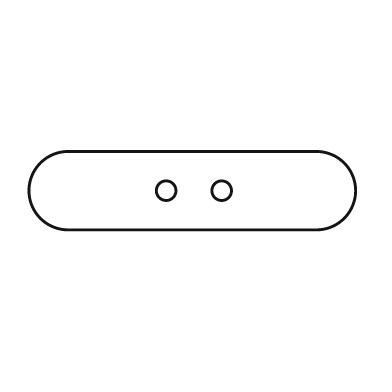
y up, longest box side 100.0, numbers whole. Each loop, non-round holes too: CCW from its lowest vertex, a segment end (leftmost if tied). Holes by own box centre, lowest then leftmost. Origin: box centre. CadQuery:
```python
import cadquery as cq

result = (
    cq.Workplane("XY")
    .moveTo(-38.0, -12.0)
    .lineTo(38.0, -12.0)
    .threePointArc((50.0, 0.0), (38.0, 12.0))
    .lineTo(-38.0, 12.0)
    .threePointArc((-50.0, 0.0), (-38.0, -12.0))
    .close()
    .moveTo(-8.0, 0.0)
    .circle(3.0)
    .moveTo(9.0, 0.0)
    .circle(3.0)
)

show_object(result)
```